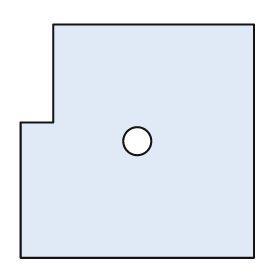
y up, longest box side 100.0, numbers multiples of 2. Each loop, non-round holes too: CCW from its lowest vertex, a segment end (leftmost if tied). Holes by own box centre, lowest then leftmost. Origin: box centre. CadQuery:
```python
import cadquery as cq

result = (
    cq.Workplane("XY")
    .moveTo(-50.0, -50.0)
    .lineTo(50.0, -50.0)
    .lineTo(50.0, 50.0)
    .lineTo(-36.0, 50.0)
    .lineTo(-36.0, 8.0)
    .lineTo(-50.0, 8.0)
    .close()
    .moveTo(0.0, 0.0)
    .circle(6.0)
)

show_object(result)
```